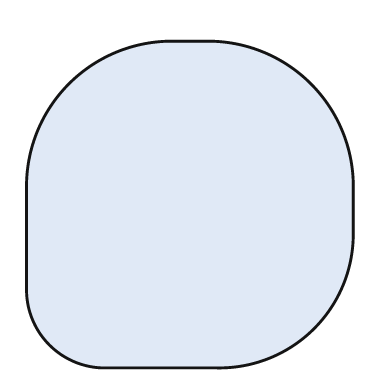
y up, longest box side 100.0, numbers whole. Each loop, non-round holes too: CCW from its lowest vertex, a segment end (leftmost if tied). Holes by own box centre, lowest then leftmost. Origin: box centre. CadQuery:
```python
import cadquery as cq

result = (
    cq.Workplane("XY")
    .moveTo(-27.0, -50.0)
    .lineTo(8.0, -50.0)
    .threePointArc((38.0, -38.0), (50.0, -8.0))
    .lineTo(50.0, 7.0)
    .threePointArc((37.0, 37.0), (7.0, 50.0))
    .lineTo(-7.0, 50.0)
    .threePointArc((-37.0, 37.0), (-50.0, 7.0))
    .lineTo(-50.0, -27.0)
    .threePointArc((-43.0, -43.0), (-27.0, -50.0))
    .close()
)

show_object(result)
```